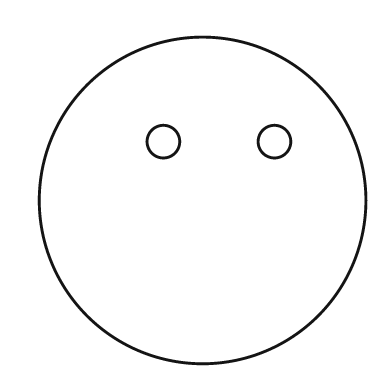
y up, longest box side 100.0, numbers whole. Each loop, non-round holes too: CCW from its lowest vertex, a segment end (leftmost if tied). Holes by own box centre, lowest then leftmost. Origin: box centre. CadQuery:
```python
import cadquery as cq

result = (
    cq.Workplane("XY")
    .moveTo(0.0, 0.0)
    .circle(50.0)
    .moveTo(-12.0, 18.0)
    .circle(5.0)
    .moveTo(22.0, 18.0)
    .circle(5.0)
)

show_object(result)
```